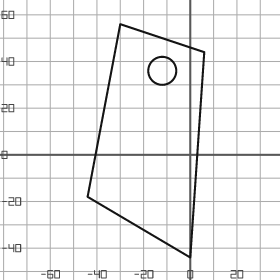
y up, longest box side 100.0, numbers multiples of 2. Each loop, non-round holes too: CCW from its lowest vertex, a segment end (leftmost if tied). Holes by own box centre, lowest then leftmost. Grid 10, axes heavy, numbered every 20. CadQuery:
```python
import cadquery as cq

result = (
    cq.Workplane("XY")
    .moveTo(0.0, -44.0)
    .lineTo(6.0, 44.0)
    .lineTo(-30.0, 56.0)
    .lineTo(-44.0, -18.0)
    .close()
    .moveTo(-12.0, 36.0)
    .circle(6.0)
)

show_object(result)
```